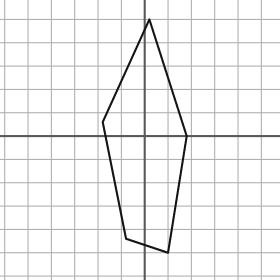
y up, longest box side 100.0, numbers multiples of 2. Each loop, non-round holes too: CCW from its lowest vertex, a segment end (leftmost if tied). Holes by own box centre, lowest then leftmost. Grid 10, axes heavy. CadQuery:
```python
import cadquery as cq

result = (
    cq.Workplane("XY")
    .moveTo(10.0, -50.0)
    .lineTo(18.0, 0.0)
    .lineTo(2.0, 50.0)
    .lineTo(-18.0, 6.0)
    .lineTo(-8.0, -44.0)
    .close()
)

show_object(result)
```